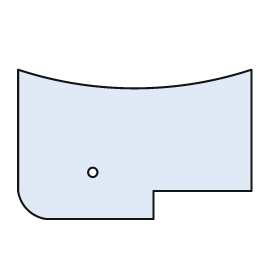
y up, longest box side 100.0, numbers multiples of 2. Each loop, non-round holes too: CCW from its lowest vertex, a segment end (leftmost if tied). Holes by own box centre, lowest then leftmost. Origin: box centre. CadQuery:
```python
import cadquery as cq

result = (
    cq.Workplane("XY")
    .moveTo(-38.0, -32.0)
    .lineTo(8.0, -32.0)
    .lineTo(8.0, -20.0)
    .lineTo(50.0, -20.0)
    .lineTo(50.0, 32.0)
    .threePointArc((0.0, 24.0), (-50.0, 32.0))
    .lineTo(-50.0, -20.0)
    .threePointArc((-46.0, -28.0), (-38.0, -32.0))
    .close()
    .moveTo(-18.0, -12.0)
    .circle(2.0)
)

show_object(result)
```